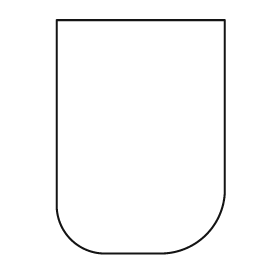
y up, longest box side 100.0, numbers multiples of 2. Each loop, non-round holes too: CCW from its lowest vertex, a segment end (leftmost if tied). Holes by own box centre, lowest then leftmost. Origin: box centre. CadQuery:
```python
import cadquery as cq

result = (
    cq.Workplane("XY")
    .moveTo(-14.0, -50.0)
    .lineTo(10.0, -50.0)
    .threePointArc((28.0, -42.0), (36.0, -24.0))
    .lineTo(36.0, 50.0)
    .lineTo(-36.0, 50.0)
    .lineTo(-36.0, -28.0)
    .threePointArc((-30.0, -44.0), (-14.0, -50.0))
    .close()
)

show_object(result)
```